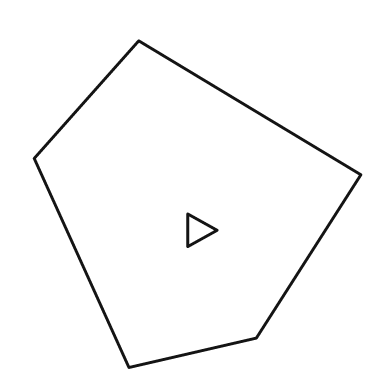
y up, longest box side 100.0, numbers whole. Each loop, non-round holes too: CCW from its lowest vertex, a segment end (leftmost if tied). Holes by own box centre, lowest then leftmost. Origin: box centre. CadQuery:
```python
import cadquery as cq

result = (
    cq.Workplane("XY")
    .moveTo(-21.0, -50.0)
    .lineTo(18.0, -41.0)
    .lineTo(50.0, 9.0)
    .lineTo(-18.0, 50.0)
    .lineTo(-50.0, 14.0)
    .close()
    .moveTo(-3.0, -13.0)
    .lineTo(6.0, -8.0)
    .lineTo(-3.0, -3.0)
    .close()
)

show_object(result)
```